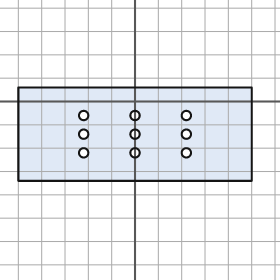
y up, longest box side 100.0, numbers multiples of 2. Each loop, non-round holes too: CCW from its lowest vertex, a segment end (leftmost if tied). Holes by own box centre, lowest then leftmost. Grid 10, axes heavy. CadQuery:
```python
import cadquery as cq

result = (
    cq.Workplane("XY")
    .moveTo(-50.0, -34.0)
    .lineTo(50.0, -34.0)
    .lineTo(50.0, 6.0)
    .lineTo(-50.0, 6.0)
    .close()
    .moveTo(-22.0, -22.0)
    .circle(2.0)
    .moveTo(0.0, -22.0)
    .circle(2.0)
    .moveTo(22.0, -22.0)
    .circle(2.0)
    .moveTo(-22.0, -14.0)
    .circle(2.0)
    .moveTo(0.0, -14.0)
    .circle(2.0)
    .moveTo(22.0, -14.0)
    .circle(2.0)
    .moveTo(-22.0, -6.0)
    .circle(2.0)
    .moveTo(0.0, -6.0)
    .circle(2.0)
    .moveTo(22.0, -6.0)
    .circle(2.0)
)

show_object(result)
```